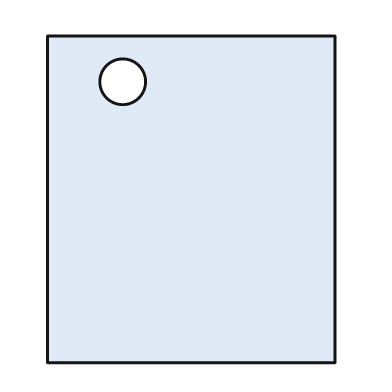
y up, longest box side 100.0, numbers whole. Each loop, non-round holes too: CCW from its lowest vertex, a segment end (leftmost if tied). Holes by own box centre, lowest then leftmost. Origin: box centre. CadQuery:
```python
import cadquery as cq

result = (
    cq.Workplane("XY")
    .moveTo(-44.0, -50.0)
    .lineTo(44.0, -50.0)
    .lineTo(44.0, 50.0)
    .lineTo(-44.0, 50.0)
    .close()
    .moveTo(-21.0, 36.0)
    .circle(7.0)
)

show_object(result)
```